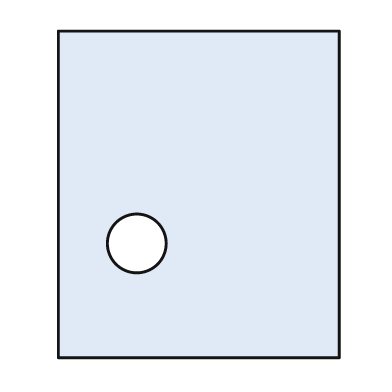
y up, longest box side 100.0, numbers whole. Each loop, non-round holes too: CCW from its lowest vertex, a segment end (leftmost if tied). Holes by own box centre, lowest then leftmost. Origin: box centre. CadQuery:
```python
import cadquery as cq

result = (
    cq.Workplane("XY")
    .moveTo(-43.0, -50.0)
    .lineTo(43.0, -50.0)
    .lineTo(43.0, 50.0)
    .lineTo(-43.0, 50.0)
    .close()
    .moveTo(-19.0, -15.0)
    .circle(9.0)
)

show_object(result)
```